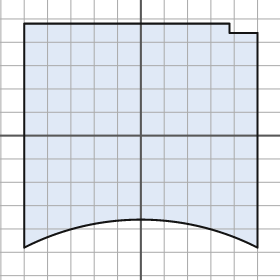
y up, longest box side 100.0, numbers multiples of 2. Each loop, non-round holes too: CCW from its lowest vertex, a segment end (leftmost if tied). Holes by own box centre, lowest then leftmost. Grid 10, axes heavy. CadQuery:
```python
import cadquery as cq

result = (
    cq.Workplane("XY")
    .moveTo(-50.0, -48.0)
    .threePointArc((0.0, -36.0), (50.0, -48.0))
    .lineTo(50.0, 44.0)
    .lineTo(38.0, 44.0)
    .lineTo(38.0, 48.0)
    .lineTo(-50.0, 48.0)
    .close()
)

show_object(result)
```